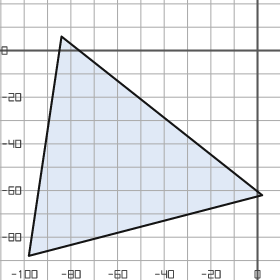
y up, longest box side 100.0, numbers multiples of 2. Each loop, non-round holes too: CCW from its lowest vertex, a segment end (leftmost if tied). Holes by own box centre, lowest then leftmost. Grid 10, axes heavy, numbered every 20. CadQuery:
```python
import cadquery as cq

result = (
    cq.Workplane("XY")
    .moveTo(-98.0, -88.0)
    .lineTo(2.0, -62.0)
    .lineTo(-84.0, 6.0)
    .close()
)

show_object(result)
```